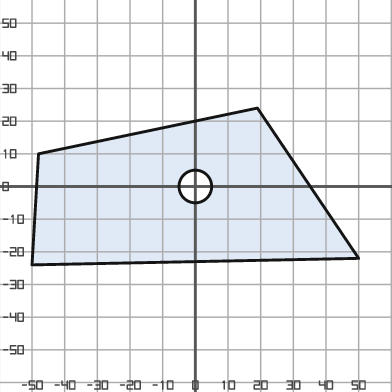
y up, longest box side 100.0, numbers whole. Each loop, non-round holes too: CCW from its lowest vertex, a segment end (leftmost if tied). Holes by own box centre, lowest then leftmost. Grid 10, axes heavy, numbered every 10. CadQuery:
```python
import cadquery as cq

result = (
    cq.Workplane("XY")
    .moveTo(-50.0, -24.0)
    .lineTo(50.0, -22.0)
    .lineTo(19.0, 24.0)
    .lineTo(-48.0, 10.0)
    .close()
    .moveTo(0.0, 0.0)
    .circle(5.0)
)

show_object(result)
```